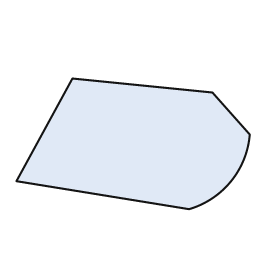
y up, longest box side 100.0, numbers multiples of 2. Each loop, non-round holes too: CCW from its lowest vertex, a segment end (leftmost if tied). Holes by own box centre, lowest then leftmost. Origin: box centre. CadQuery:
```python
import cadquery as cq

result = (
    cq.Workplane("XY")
    .moveTo(24.0, -28.0)
    .threePointArc((42.0, -16.0), (50.0, 4.0))
    .lineTo(34.0, 22.0)
    .lineTo(-26.0, 28.0)
    .lineTo(-50.0, -16.0)
    .close()
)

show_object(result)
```